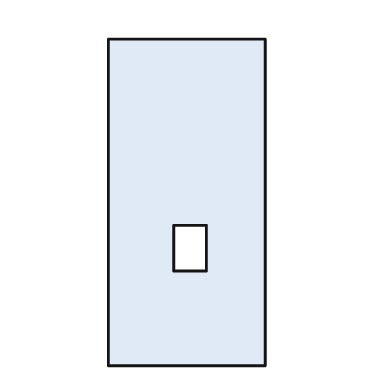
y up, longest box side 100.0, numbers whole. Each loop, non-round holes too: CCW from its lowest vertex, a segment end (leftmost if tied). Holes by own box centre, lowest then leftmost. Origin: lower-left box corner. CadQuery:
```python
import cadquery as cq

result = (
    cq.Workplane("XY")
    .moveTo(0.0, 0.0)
    .lineTo(48.0, 0.0)
    .lineTo(48.0, 100.0)
    .lineTo(0.0, 100.0)
    .close()
    .moveTo(20.0, 29.0)
    .lineTo(30.0, 29.0)
    .lineTo(30.0, 43.0)
    .lineTo(20.0, 43.0)
    .close()
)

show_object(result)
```